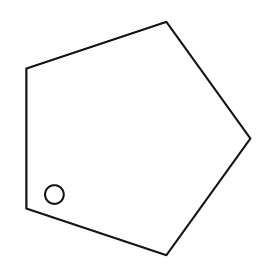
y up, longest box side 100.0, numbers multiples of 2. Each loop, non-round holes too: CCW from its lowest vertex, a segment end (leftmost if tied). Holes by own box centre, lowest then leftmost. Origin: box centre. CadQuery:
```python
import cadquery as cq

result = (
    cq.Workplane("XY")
    .moveTo(12.0, -50.0)
    .lineTo(48.0, 0.0)
    .lineTo(12.0, 50.0)
    .lineTo(-48.0, 30.0)
    .lineTo(-48.0, -30.0)
    .close()
    .moveTo(-36.0, -24.0)
    .circle(4.0)
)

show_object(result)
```